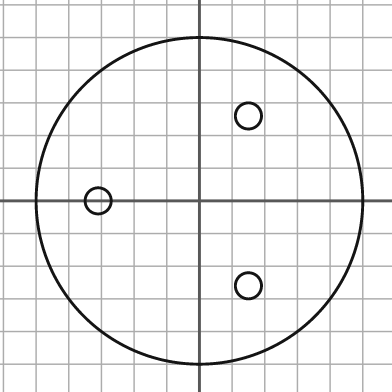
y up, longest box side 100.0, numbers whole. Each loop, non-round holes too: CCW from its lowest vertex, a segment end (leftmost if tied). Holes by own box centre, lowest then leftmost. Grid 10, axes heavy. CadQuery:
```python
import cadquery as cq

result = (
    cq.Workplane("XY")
    .moveTo(0.0, 0.0)
    .circle(50.0)
    .moveTo(15.0, -26.0)
    .circle(4.0)
    .moveTo(-31.0, 0.0)
    .circle(4.0)
    .moveTo(15.0, 26.0)
    .circle(4.0)
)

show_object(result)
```